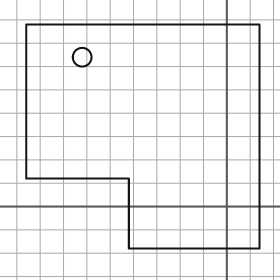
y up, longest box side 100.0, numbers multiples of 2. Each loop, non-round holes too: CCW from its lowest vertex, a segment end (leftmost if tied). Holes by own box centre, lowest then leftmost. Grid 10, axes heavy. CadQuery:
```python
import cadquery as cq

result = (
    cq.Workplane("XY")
    .moveTo(-42.0, -18.0)
    .lineTo(14.0, -18.0)
    .lineTo(14.0, 78.0)
    .lineTo(-86.0, 78.0)
    .lineTo(-86.0, 12.0)
    .lineTo(-42.0, 12.0)
    .close()
    .moveTo(-62.0, 64.0)
    .circle(4.0)
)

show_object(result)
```